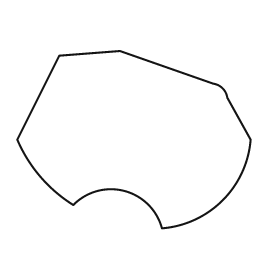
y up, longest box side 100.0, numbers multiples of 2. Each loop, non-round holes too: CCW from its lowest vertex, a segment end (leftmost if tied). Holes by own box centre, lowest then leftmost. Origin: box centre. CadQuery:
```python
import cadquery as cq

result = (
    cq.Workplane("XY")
    .moveTo(12.0, -38.0)
    .threePointArc((38.0, -26.0), (50.0, 0.0))
    .lineTo(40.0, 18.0)
    .threePointArc((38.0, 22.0), (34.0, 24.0))
    .lineTo(-6.0, 38.0)
    .lineTo(-32.0, 36.0)
    .lineTo(-50.0, 0.0)
    .threePointArc((-40.0, -16.0), (-26.0, -28.0))
    .threePointArc((-4.0, -22.0), (12.0, -38.0))
    .close()
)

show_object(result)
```